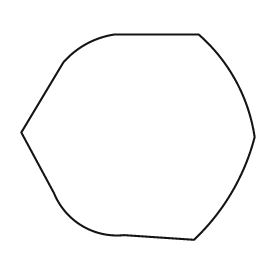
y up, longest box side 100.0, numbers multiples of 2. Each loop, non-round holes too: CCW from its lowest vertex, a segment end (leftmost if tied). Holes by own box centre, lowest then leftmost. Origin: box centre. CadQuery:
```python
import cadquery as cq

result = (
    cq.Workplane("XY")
    .moveTo(24.0, -44.0)
    .threePointArc((40.0, -24.0), (50.0, 0.0))
    .threePointArc((42.0, 24.0), (26.0, 44.0))
    .lineTo(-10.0, 44.0)
    .threePointArc((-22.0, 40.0), (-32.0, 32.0))
    .lineTo(-50.0, 2.0)
    .lineTo(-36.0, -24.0)
    .threePointArc((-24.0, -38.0), (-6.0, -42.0))
    .close()
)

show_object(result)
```